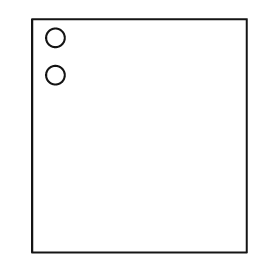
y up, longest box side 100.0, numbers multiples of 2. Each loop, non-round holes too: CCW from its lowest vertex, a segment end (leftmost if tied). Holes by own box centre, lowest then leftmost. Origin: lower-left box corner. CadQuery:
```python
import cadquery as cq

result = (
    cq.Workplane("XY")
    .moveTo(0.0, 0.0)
    .lineTo(92.0, 0.0)
    .lineTo(92.0, 100.0)
    .lineTo(0.0, 100.0)
    .close()
    .moveTo(10.0, 76.0)
    .circle(4.0)
    .moveTo(10.0, 92.0)
    .circle(4.0)
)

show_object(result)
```